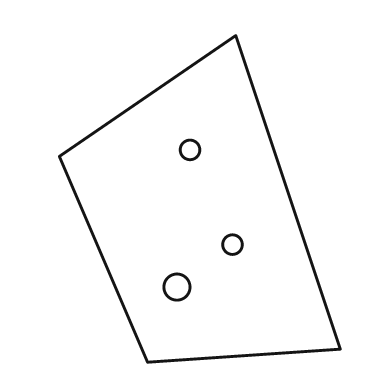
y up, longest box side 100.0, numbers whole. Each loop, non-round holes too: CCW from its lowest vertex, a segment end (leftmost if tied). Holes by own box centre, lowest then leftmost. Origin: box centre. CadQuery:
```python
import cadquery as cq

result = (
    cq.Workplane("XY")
    .moveTo(-16.0, -50.0)
    .lineTo(43.0, -46.0)
    .lineTo(11.0, 50.0)
    .lineTo(-43.0, 13.0)
    .close()
    .moveTo(-7.0, -27.0)
    .circle(4.0)
    .moveTo(10.0, -14.0)
    .circle(3.0)
    .moveTo(-3.0, 15.0)
    .circle(3.0)
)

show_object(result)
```